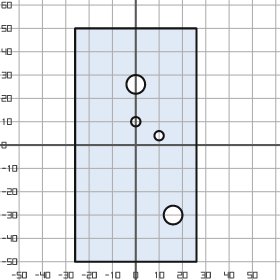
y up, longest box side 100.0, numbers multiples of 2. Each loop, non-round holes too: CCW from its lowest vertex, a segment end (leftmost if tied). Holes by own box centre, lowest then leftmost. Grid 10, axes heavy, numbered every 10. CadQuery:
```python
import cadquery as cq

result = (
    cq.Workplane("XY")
    .moveTo(-26.0, -50.0)
    .lineTo(26.0, -50.0)
    .lineTo(26.0, 50.0)
    .lineTo(-26.0, 50.0)
    .close()
    .moveTo(16.0, -30.0)
    .circle(4.0)
    .moveTo(10.0, 4.0)
    .circle(2.0)
    .moveTo(0.0, 10.0)
    .circle(2.0)
    .moveTo(0.0, 26.0)
    .circle(4.0)
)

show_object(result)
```